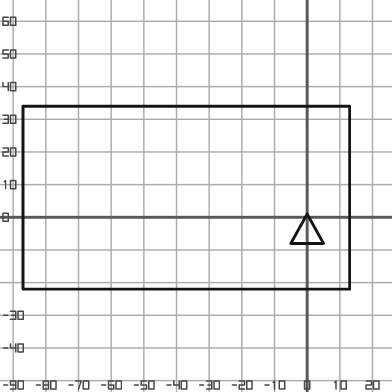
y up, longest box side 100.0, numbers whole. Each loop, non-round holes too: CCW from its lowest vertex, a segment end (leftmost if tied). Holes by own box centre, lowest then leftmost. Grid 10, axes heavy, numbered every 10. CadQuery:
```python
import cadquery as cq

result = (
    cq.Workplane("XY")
    .moveTo(-87.0, -22.0)
    .lineTo(13.0, -22.0)
    .lineTo(13.0, 34.0)
    .lineTo(-87.0, 34.0)
    .close()
    .moveTo(-5.0, -8.0)
    .lineTo(5.0, -8.0)
    .lineTo(0.0, 1.0)
    .close()
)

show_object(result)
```